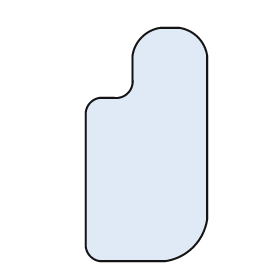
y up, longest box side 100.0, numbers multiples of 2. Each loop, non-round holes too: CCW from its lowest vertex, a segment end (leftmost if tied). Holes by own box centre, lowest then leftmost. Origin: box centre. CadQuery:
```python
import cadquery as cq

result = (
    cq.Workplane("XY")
    .moveTo(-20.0, -50.0)
    .lineTo(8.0, -50.0)
    .threePointArc((20.0, -44.0), (26.0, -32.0))
    .lineTo(26.0, 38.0)
    .threePointArc((22.0, 46.0), (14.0, 50.0))
    .lineTo(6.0, 50.0)
    .threePointArc((-2.0, 46.0), (-6.0, 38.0))
    .lineTo(-6.0, 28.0)
    .threePointArc((-8.0, 22.0), (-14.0, 20.0))
    .lineTo(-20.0, 20.0)
    .threePointArc((-24.0, 18.0), (-26.0, 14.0))
    .lineTo(-26.0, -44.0)
    .threePointArc((-24.0, -48.0), (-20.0, -50.0))
    .close()
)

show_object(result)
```